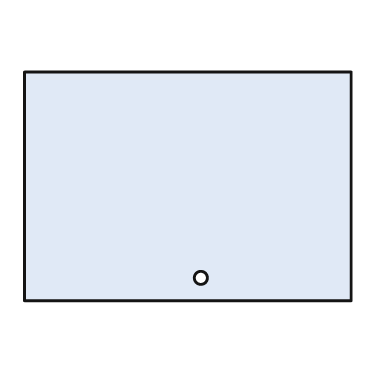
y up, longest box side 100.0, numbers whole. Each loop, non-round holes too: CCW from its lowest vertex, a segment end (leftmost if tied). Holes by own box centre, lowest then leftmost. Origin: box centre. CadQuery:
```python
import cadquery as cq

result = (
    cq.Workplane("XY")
    .moveTo(-50.0, -35.0)
    .lineTo(50.0, -35.0)
    .lineTo(50.0, 35.0)
    .lineTo(-50.0, 35.0)
    .close()
    .moveTo(4.0, -28.0)
    .circle(2.0)
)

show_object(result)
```